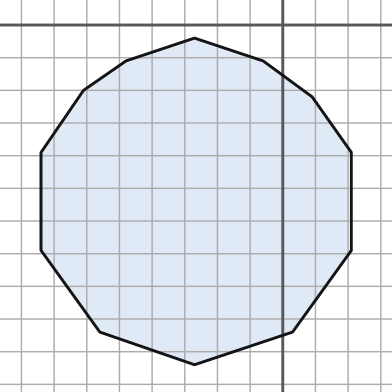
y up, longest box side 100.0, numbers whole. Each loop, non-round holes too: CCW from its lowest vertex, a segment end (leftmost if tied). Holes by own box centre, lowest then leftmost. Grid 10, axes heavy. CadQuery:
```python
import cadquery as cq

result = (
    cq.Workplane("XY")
    .moveTo(-27.0, -104.0)
    .lineTo(3.0, -94.0)
    .lineTo(21.0, -69.0)
    .lineTo(21.0, -39.0)
    .lineTo(9.0, -22.0)
    .lineTo(-6.0, -11.0)
    .lineTo(-27.0, -4.0)
    .lineTo(-48.0, -11.0)
    .lineTo(-61.0, -20.0)
    .lineTo(-74.0, -39.0)
    .lineTo(-74.0, -69.0)
    .lineTo(-56.0, -94.0)
    .close()
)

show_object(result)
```